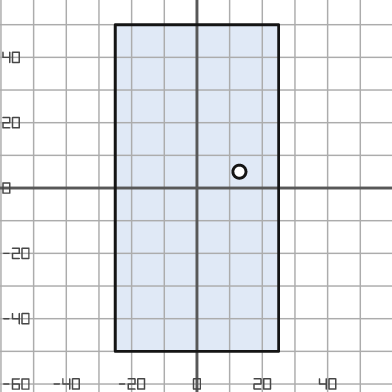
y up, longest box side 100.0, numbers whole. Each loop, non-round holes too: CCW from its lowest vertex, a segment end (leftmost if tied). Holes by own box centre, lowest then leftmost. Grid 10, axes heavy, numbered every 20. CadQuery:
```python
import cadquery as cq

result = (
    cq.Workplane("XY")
    .moveTo(-25.0, -50.0)
    .lineTo(25.0, -50.0)
    .lineTo(25.0, 50.0)
    .lineTo(-25.0, 50.0)
    .close()
    .moveTo(13.0, 5.0)
    .circle(2.0)
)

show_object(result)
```